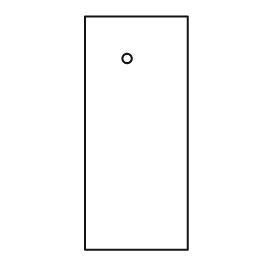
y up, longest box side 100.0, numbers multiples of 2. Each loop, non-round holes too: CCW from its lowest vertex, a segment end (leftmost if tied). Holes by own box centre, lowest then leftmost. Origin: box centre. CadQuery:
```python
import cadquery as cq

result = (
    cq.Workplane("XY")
    .moveTo(-22.0, -50.0)
    .lineTo(22.0, -50.0)
    .lineTo(22.0, 50.0)
    .lineTo(-22.0, 50.0)
    .close()
    .moveTo(-4.0, 32.0)
    .circle(2.0)
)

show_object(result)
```